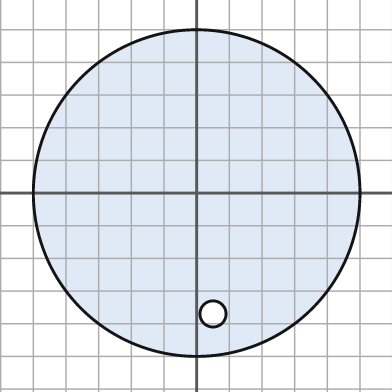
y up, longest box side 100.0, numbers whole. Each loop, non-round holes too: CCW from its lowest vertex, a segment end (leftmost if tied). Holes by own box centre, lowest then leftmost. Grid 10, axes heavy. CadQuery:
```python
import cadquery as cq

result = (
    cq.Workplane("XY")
    .moveTo(0.0, 0.0)
    .circle(50.0)
    .moveTo(5.0, -37.0)
    .circle(4.0)
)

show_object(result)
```